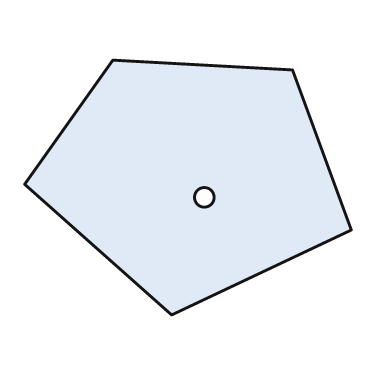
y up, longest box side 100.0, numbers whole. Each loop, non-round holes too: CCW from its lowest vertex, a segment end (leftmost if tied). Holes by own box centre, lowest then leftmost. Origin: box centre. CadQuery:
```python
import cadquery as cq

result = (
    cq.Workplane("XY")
    .moveTo(-5.0, -39.0)
    .lineTo(50.0, -13.0)
    .lineTo(32.0, 36.0)
    .lineTo(-23.0, 39.0)
    .lineTo(-50.0, 1.0)
    .close()
    .moveTo(5.0, -3.0)
    .circle(3.0)
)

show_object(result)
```